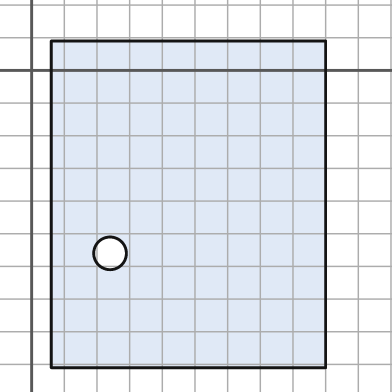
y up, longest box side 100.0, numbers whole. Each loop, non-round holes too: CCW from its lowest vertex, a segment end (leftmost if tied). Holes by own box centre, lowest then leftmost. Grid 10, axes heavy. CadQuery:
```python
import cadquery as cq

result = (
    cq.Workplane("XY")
    .moveTo(6.0, -91.0)
    .lineTo(90.0, -91.0)
    .lineTo(90.0, 9.0)
    .lineTo(6.0, 9.0)
    .close()
    .moveTo(24.0, -56.0)
    .circle(5.0)
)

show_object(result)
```